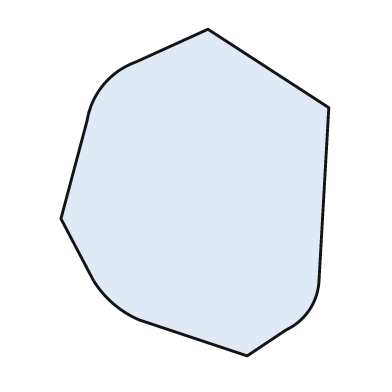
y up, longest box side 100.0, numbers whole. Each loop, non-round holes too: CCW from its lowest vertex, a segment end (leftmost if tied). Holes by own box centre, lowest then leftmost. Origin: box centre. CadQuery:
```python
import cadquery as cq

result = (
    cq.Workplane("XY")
    .moveTo(16.0, -50.0)
    .lineTo(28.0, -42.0)
    .threePointArc((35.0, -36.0), (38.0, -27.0))
    .lineTo(41.0, 26.0)
    .lineTo(4.0, 50.0)
    .lineTo(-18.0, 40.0)
    .threePointArc((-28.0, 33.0), (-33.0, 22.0))
    .lineTo(-41.0, -8.0)
    .lineTo(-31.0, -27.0)
    .threePointArc((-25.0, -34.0), (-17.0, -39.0))
    .close()
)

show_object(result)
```